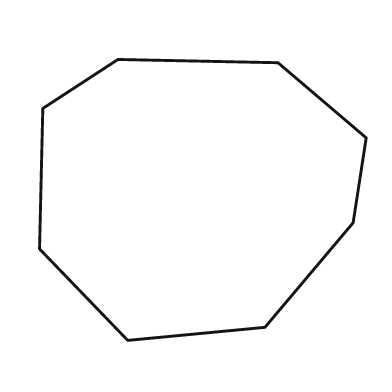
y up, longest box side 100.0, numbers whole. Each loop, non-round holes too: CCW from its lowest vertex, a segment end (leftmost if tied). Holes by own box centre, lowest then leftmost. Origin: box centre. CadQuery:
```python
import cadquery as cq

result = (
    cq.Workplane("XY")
    .moveTo(-23.0, -43.0)
    .lineTo(19.0, -39.0)
    .lineTo(46.0, -7.0)
    .lineTo(50.0, 19.0)
    .lineTo(23.0, 42.0)
    .lineTo(-26.0, 43.0)
    .lineTo(-49.0, 28.0)
    .lineTo(-50.0, -15.0)
    .close()
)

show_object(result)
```